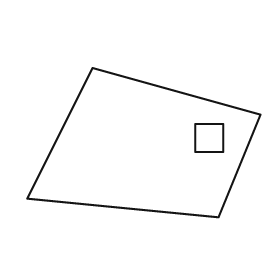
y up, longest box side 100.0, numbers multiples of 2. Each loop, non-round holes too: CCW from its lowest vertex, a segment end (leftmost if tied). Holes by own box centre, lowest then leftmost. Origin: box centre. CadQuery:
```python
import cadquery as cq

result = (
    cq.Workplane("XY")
    .moveTo(32.0, -32.0)
    .lineTo(50.0, 12.0)
    .lineTo(-22.0, 32.0)
    .lineTo(-50.0, -24.0)
    .close()
    .moveTo(22.0, -4.0)
    .lineTo(34.0, -4.0)
    .lineTo(34.0, 8.0)
    .lineTo(22.0, 8.0)
    .close()
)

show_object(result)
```